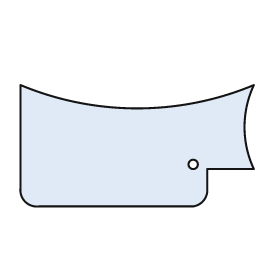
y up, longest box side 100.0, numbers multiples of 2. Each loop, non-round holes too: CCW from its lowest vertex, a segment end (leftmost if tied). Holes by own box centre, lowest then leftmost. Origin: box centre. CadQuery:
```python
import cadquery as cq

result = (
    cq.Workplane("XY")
    .moveTo(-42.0, -26.0)
    .lineTo(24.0, -26.0)
    .threePointArc((28.0, -24.0), (30.0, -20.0))
    .lineTo(30.0, -10.0)
    .lineTo(50.0, -10.0)
    .threePointArc((46.0, 8.0), (50.0, 26.0))
    .threePointArc((0.0, 16.0), (-50.0, 26.0))
    .lineTo(-50.0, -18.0)
    .threePointArc((-48.0, -24.0), (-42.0, -26.0))
    .close()
    .moveTo(24.0, -8.0)
    .circle(2.0)
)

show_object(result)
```